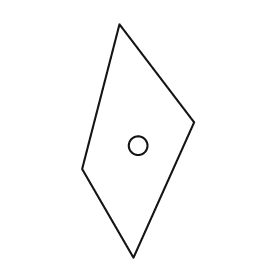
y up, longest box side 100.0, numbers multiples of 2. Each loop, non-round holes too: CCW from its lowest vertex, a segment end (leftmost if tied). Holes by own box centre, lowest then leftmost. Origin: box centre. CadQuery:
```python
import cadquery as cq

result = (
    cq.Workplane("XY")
    .moveTo(-2.0, -50.0)
    .lineTo(24.0, 8.0)
    .lineTo(-8.0, 50.0)
    .lineTo(-24.0, -12.0)
    .close()
    .moveTo(0.0, -2.0)
    .circle(4.0)
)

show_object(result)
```